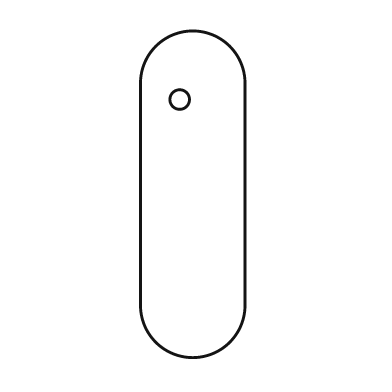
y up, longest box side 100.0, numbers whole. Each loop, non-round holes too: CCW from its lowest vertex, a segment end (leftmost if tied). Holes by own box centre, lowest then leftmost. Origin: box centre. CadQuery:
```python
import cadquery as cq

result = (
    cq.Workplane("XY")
    .moveTo(-16.0, -34.0)
    .threePointArc((0.0, -50.0), (16.0, -34.0))
    .lineTo(16.0, 34.0)
    .threePointArc((0.0, 50.0), (-16.0, 34.0))
    .close()
    .moveTo(-4.0, 29.0)
    .circle(3.0)
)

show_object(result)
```